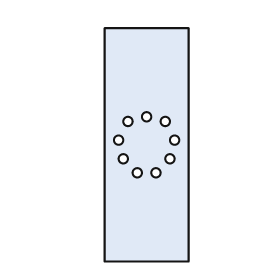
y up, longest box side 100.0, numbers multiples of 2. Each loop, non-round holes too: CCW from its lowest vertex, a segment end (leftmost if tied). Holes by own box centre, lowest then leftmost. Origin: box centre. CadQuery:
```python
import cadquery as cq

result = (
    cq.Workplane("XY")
    .moveTo(-18.0, -50.0)
    .lineTo(18.0, -50.0)
    .lineTo(18.0, 50.0)
    .lineTo(-18.0, 50.0)
    .close()
    .moveTo(-4.0, -12.0)
    .circle(2.0)
    .moveTo(4.0, -12.0)
    .circle(2.0)
    .moveTo(-10.0, -6.0)
    .circle(2.0)
    .moveTo(10.0, -6.0)
    .circle(2.0)
    .moveTo(-12.0, 2.0)
    .circle(2.0)
    .moveTo(12.0, 2.0)
    .circle(2.0)
    .moveTo(-8.0, 10.0)
    .circle(2.0)
    .moveTo(8.0, 10.0)
    .circle(2.0)
    .moveTo(0.0, 12.0)
    .circle(2.0)
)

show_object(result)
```